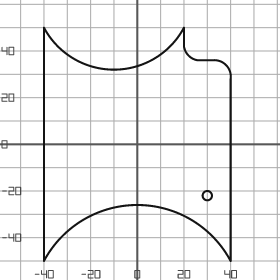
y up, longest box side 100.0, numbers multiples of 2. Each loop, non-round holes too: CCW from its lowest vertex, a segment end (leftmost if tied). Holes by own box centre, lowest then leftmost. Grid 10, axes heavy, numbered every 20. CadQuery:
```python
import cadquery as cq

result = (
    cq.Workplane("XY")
    .moveTo(-40.0, -50.0)
    .threePointArc((0.0, -26.0), (40.0, -50.0))
    .lineTo(40.0, 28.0)
    .threePointArc((38.0, 34.0), (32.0, 36.0))
    .lineTo(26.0, 36.0)
    .threePointArc((22.0, 38.0), (20.0, 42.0))
    .lineTo(20.0, 50.0)
    .threePointArc((-10.0, 32.0), (-40.0, 50.0))
    .close()
    .moveTo(30.0, -22.0)
    .circle(2.0)
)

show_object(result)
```